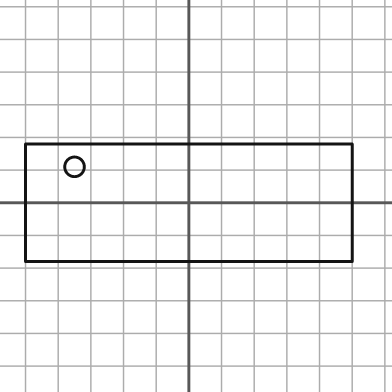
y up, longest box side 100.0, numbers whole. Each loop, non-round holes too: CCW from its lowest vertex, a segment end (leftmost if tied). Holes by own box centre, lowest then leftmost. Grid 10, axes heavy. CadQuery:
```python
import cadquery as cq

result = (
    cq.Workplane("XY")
    .moveTo(-50.0, -18.0)
    .lineTo(50.0, -18.0)
    .lineTo(50.0, 18.0)
    .lineTo(-50.0, 18.0)
    .close()
    .moveTo(-35.0, 11.0)
    .circle(3.0)
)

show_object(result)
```